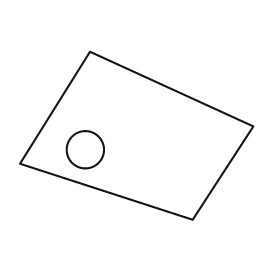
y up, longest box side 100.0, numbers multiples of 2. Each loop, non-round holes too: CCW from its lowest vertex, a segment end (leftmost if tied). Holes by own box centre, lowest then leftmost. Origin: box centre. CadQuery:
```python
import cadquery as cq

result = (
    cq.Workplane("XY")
    .moveTo(24.0, -36.0)
    .lineTo(50.0, 4.0)
    .lineTo(-20.0, 36.0)
    .lineTo(-50.0, -12.0)
    .close()
    .moveTo(-22.0, -6.0)
    .circle(8.0)
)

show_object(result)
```